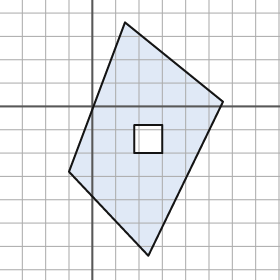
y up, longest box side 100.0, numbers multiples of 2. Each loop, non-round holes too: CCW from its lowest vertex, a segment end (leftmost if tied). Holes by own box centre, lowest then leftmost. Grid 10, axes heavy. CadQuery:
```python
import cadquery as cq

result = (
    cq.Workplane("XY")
    .moveTo(24.0, -64.0)
    .lineTo(56.0, 2.0)
    .lineTo(14.0, 36.0)
    .lineTo(-10.0, -28.0)
    .close()
    .moveTo(18.0, -20.0)
    .lineTo(30.0, -20.0)
    .lineTo(30.0, -8.0)
    .lineTo(18.0, -8.0)
    .close()
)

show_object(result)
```